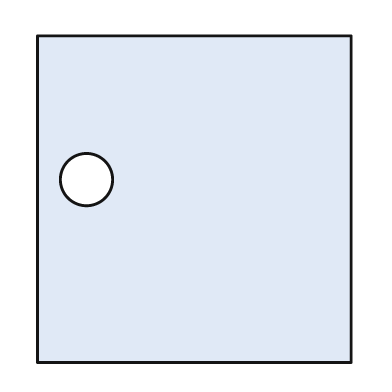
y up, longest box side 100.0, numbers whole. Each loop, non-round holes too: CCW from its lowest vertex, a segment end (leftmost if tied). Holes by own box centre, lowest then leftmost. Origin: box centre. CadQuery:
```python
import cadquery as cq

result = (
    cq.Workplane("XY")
    .moveTo(-48.0, -50.0)
    .lineTo(48.0, -50.0)
    .lineTo(48.0, 50.0)
    .lineTo(-48.0, 50.0)
    .close()
    .moveTo(-33.0, 6.0)
    .circle(8.0)
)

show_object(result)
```